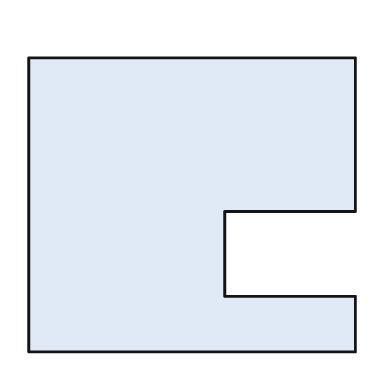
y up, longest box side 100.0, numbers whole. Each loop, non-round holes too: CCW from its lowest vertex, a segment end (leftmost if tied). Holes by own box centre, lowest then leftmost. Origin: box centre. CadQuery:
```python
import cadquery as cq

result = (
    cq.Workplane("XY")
    .moveTo(-50.0, -45.0)
    .lineTo(50.0, -45.0)
    .lineTo(50.0, -28.0)
    .lineTo(10.0, -28.0)
    .lineTo(10.0, -2.0)
    .lineTo(50.0, -2.0)
    .lineTo(50.0, 45.0)
    .lineTo(-50.0, 45.0)
    .close()
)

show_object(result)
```